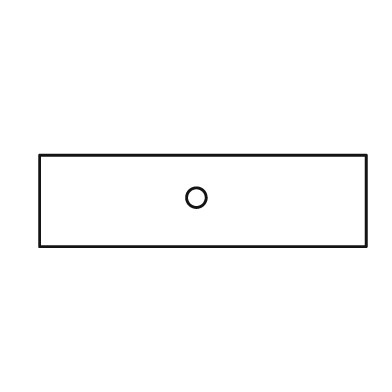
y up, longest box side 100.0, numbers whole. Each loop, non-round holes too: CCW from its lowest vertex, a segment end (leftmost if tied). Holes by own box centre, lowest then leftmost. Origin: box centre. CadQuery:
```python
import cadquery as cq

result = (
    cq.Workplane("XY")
    .moveTo(-50.0, -14.0)
    .lineTo(50.0, -14.0)
    .lineTo(50.0, 14.0)
    .lineTo(-50.0, 14.0)
    .close()
    .moveTo(-2.0, 1.0)
    .circle(3.0)
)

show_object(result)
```